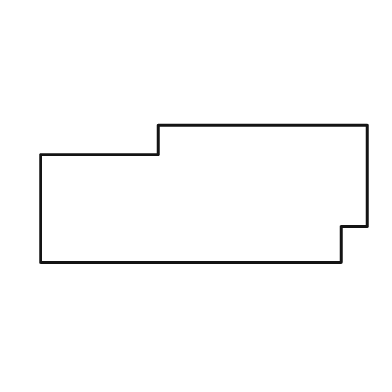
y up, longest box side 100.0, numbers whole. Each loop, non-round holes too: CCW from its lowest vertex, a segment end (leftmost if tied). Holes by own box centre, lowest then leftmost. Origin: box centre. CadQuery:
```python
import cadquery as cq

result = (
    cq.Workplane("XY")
    .moveTo(-50.0, -21.0)
    .lineTo(42.0, -21.0)
    .lineTo(42.0, -10.0)
    .lineTo(50.0, -10.0)
    .lineTo(50.0, 21.0)
    .lineTo(-14.0, 21.0)
    .lineTo(-14.0, 12.0)
    .lineTo(-50.0, 12.0)
    .close()
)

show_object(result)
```